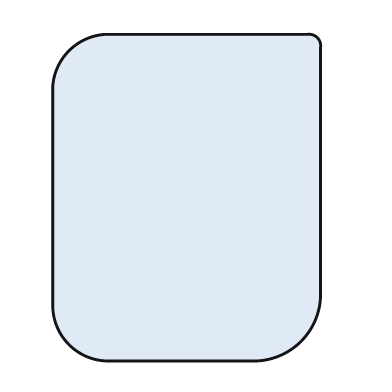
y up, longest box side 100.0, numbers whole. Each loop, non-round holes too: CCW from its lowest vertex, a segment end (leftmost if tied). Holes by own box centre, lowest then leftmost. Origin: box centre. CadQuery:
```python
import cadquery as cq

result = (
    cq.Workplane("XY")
    .moveTo(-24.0, -50.0)
    .lineTo(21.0, -50.0)
    .threePointArc((35.0, -44.0), (41.0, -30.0))
    .lineTo(41.0, 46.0)
    .threePointArc((40.0, 49.0), (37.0, 50.0))
    .lineTo(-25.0, 50.0)
    .threePointArc((-36.0, 45.0), (-41.0, 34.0))
    .lineTo(-41.0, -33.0)
    .threePointArc((-36.0, -45.0), (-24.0, -50.0))
    .close()
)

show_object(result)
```